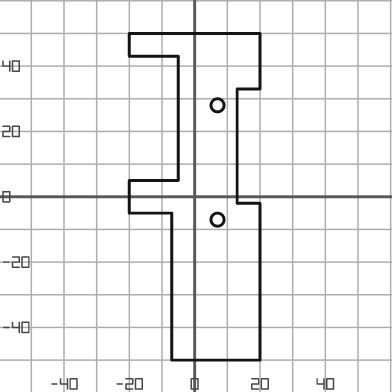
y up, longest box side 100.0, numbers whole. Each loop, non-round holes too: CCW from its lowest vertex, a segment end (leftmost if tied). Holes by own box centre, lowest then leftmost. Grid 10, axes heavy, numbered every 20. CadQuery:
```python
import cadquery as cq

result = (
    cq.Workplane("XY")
    .moveTo(-7.0, -50.0)
    .lineTo(20.0, -50.0)
    .lineTo(20.0, -2.0)
    .lineTo(13.0, -2.0)
    .lineTo(13.0, 33.0)
    .lineTo(20.0, 33.0)
    .lineTo(20.0, 50.0)
    .lineTo(-20.0, 50.0)
    .lineTo(-20.0, 43.0)
    .lineTo(-5.0, 43.0)
    .lineTo(-5.0, 5.0)
    .lineTo(-20.0, 5.0)
    .lineTo(-20.0, -5.0)
    .lineTo(-7.0, -5.0)
    .close()
    .moveTo(7.0, -7.0)
    .circle(2.0)
    .moveTo(7.0, 28.0)
    .circle(2.0)
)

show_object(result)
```